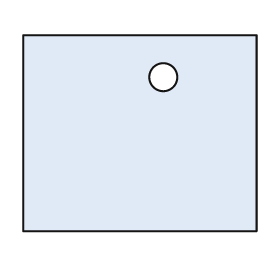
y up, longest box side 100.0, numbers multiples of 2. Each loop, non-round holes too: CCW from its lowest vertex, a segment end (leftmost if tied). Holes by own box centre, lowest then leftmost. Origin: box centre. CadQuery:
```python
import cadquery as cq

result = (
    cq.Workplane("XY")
    .moveTo(-50.0, -42.0)
    .lineTo(50.0, -42.0)
    .lineTo(50.0, 42.0)
    .lineTo(-50.0, 42.0)
    .close()
    .moveTo(10.0, 24.0)
    .circle(6.0)
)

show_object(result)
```